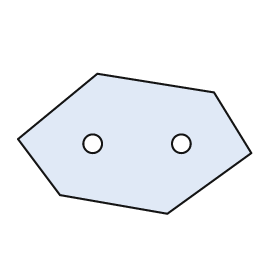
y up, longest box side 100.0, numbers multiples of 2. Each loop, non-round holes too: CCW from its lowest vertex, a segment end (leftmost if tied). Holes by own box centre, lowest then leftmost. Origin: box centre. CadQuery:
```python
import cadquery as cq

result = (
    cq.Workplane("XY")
    .moveTo(14.0, -30.0)
    .lineTo(50.0, -4.0)
    .lineTo(34.0, 22.0)
    .lineTo(-16.0, 30.0)
    .lineTo(-50.0, 2.0)
    .lineTo(-32.0, -22.0)
    .close()
    .moveTo(-18.0, 0.0)
    .circle(4.0)
    .moveTo(20.0, 0.0)
    .circle(4.0)
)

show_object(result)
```